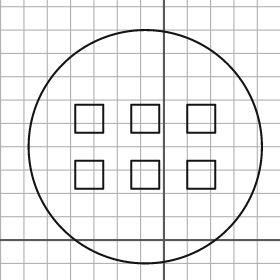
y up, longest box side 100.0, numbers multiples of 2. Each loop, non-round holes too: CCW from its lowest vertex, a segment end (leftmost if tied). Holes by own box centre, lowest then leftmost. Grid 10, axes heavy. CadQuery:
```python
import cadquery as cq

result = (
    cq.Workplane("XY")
    .moveTo(-8.0, 40.0)
    .circle(50.0)
    .moveTo(-38.0, 22.0)
    .lineTo(-26.0, 22.0)
    .lineTo(-26.0, 34.0)
    .lineTo(-38.0, 34.0)
    .close()
    .moveTo(-14.0, 22.0)
    .lineTo(-2.0, 22.0)
    .lineTo(-2.0, 34.0)
    .lineTo(-14.0, 34.0)
    .close()
    .moveTo(10.0, 22.0)
    .lineTo(22.0, 22.0)
    .lineTo(22.0, 34.0)
    .lineTo(10.0, 34.0)
    .close()
    .moveTo(-38.0, 46.0)
    .lineTo(-26.0, 46.0)
    .lineTo(-26.0, 58.0)
    .lineTo(-38.0, 58.0)
    .close()
    .moveTo(-14.0, 46.0)
    .lineTo(-2.0, 46.0)
    .lineTo(-2.0, 58.0)
    .lineTo(-14.0, 58.0)
    .close()
    .moveTo(10.0, 46.0)
    .lineTo(22.0, 46.0)
    .lineTo(22.0, 58.0)
    .lineTo(10.0, 58.0)
    .close()
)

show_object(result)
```